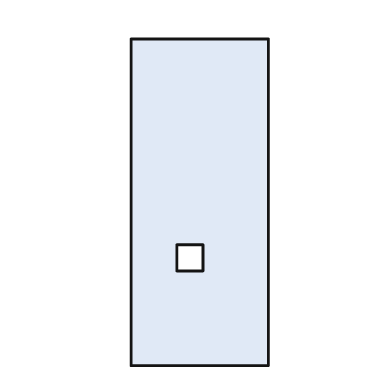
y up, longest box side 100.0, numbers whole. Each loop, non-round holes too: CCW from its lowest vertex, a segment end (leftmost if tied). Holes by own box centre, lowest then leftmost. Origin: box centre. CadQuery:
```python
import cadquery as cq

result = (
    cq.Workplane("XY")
    .moveTo(-21.0, -50.0)
    .lineTo(21.0, -50.0)
    .lineTo(21.0, 50.0)
    .lineTo(-21.0, 50.0)
    .close()
    .moveTo(-7.0, -21.0)
    .lineTo(1.0, -21.0)
    .lineTo(1.0, -13.0)
    .lineTo(-7.0, -13.0)
    .close()
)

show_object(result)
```